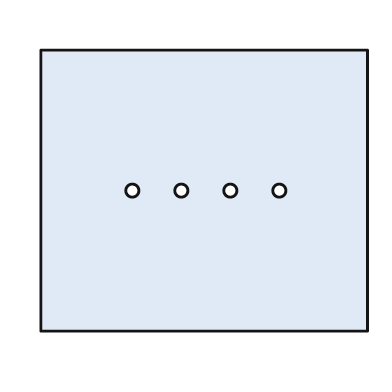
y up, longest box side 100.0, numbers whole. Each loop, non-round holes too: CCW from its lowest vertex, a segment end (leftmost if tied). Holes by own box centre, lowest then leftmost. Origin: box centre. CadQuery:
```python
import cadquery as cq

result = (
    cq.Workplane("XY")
    .moveTo(-50.0, -43.0)
    .lineTo(50.0, -43.0)
    .lineTo(50.0, 43.0)
    .lineTo(-50.0, 43.0)
    .close()
    .moveTo(-22.0, 0.0)
    .circle(2.0)
    .moveTo(-7.0, 0.0)
    .circle(2.0)
    .moveTo(8.0, 0.0)
    .circle(2.0)
    .moveTo(23.0, 0.0)
    .circle(2.0)
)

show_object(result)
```